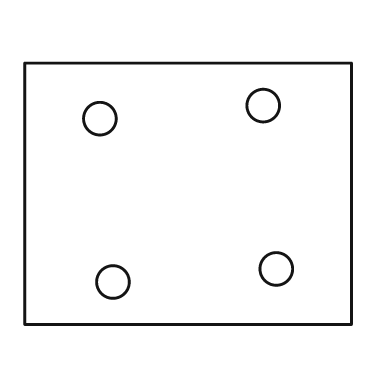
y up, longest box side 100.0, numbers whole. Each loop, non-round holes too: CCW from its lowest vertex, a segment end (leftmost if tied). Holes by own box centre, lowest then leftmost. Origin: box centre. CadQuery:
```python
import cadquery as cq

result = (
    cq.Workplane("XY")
    .moveTo(-50.0, -40.0)
    .lineTo(50.0, -40.0)
    .lineTo(50.0, 40.0)
    .lineTo(-50.0, 40.0)
    .close()
    .moveTo(-23.0, -27.0)
    .circle(5.0)
    .moveTo(27.0, -23.0)
    .circle(5.0)
    .moveTo(-27.0, 23.0)
    .circle(5.0)
    .moveTo(23.0, 27.0)
    .circle(5.0)
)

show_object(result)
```